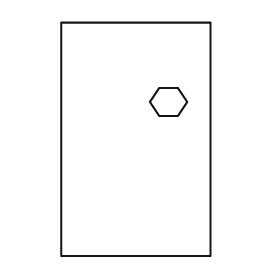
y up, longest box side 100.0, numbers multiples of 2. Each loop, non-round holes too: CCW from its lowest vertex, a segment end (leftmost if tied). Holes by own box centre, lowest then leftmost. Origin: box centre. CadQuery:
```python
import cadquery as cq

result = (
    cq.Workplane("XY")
    .moveTo(-32.0, -50.0)
    .lineTo(32.0, -50.0)
    .lineTo(32.0, 50.0)
    .lineTo(-32.0, 50.0)
    .close()
    .moveTo(10.0, 10.0)
    .lineTo(18.0, 10.0)
    .lineTo(22.0, 16.0)
    .lineTo(18.0, 22.0)
    .lineTo(10.0, 22.0)
    .lineTo(6.0, 16.0)
    .close()
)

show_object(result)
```